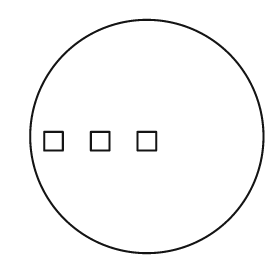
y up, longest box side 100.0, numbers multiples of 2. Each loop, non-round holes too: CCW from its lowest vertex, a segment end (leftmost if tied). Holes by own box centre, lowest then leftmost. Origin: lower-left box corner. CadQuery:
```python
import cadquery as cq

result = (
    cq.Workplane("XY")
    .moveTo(50.0, 50.0)
    .circle(50.0)
    .moveTo(6.0, 44.0)
    .lineTo(14.0, 44.0)
    .lineTo(14.0, 52.0)
    .lineTo(6.0, 52.0)
    .close()
    .moveTo(26.0, 44.0)
    .lineTo(34.0, 44.0)
    .lineTo(34.0, 52.0)
    .lineTo(26.0, 52.0)
    .close()
    .moveTo(46.0, 44.0)
    .lineTo(54.0, 44.0)
    .lineTo(54.0, 52.0)
    .lineTo(46.0, 52.0)
    .close()
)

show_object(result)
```